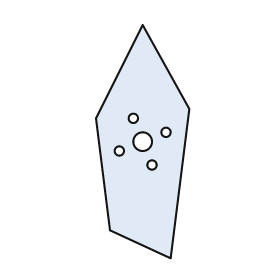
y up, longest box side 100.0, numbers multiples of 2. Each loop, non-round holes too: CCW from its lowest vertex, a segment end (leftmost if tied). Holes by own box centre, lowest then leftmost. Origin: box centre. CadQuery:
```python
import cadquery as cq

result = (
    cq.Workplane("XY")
    .moveTo(12.0, -50.0)
    .lineTo(20.0, 14.0)
    .lineTo(0.0, 50.0)
    .lineTo(-20.0, 10.0)
    .lineTo(-14.0, -38.0)
    .close()
    .moveTo(4.0, -10.0)
    .circle(2.0)
    .moveTo(-10.0, -4.0)
    .circle(2.0)
    .moveTo(0.0, 0.0)
    .circle(4.0)
    .moveTo(10.0, 4.0)
    .circle(2.0)
    .moveTo(-4.0, 10.0)
    .circle(2.0)
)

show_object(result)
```